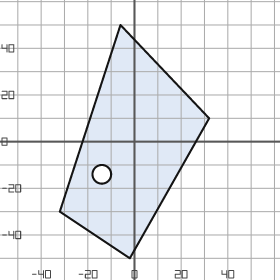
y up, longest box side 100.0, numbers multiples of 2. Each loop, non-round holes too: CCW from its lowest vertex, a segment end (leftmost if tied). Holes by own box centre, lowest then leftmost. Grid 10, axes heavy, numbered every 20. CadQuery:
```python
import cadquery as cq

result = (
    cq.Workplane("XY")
    .moveTo(-2.0, -50.0)
    .lineTo(32.0, 10.0)
    .lineTo(-6.0, 50.0)
    .lineTo(-32.0, -30.0)
    .close()
    .moveTo(-14.0, -14.0)
    .circle(4.0)
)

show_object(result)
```